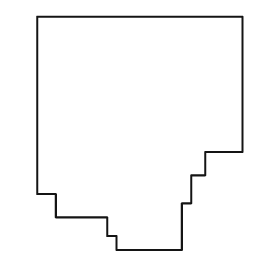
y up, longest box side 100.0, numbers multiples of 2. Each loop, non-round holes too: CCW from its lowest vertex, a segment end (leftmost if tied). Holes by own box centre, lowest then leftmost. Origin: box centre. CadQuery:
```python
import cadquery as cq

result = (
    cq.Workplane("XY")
    .moveTo(-10.0, -50.0)
    .lineTo(18.0, -50.0)
    .lineTo(18.0, -30.0)
    .lineTo(22.0, -30.0)
    .lineTo(22.0, -18.0)
    .lineTo(28.0, -18.0)
    .lineTo(28.0, -8.0)
    .lineTo(44.0, -8.0)
    .lineTo(44.0, 50.0)
    .lineTo(-44.0, 50.0)
    .lineTo(-44.0, -26.0)
    .lineTo(-36.0, -26.0)
    .lineTo(-36.0, -36.0)
    .lineTo(-14.0, -36.0)
    .lineTo(-14.0, -44.0)
    .lineTo(-10.0, -44.0)
    .close()
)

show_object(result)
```